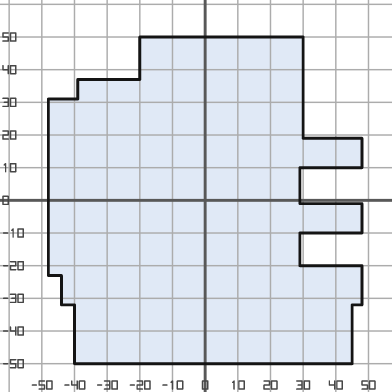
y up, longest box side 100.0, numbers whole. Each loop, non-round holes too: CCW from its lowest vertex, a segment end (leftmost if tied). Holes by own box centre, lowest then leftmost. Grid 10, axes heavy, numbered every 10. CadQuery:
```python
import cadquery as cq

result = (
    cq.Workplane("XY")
    .moveTo(-40.0, -50.0)
    .lineTo(45.0, -50.0)
    .lineTo(45.0, -32.0)
    .lineTo(48.0, -32.0)
    .lineTo(48.0, -20.0)
    .lineTo(29.0, -20.0)
    .lineTo(29.0, -10.0)
    .lineTo(48.0, -10.0)
    .lineTo(48.0, -1.0)
    .lineTo(29.0, -1.0)
    .lineTo(29.0, 10.0)
    .lineTo(48.0, 10.0)
    .lineTo(48.0, 19.0)
    .lineTo(30.0, 19.0)
    .lineTo(30.0, 50.0)
    .lineTo(-20.0, 50.0)
    .lineTo(-20.0, 37.0)
    .lineTo(-39.0, 37.0)
    .lineTo(-39.0, 31.0)
    .lineTo(-48.0, 31.0)
    .lineTo(-48.0, -23.0)
    .lineTo(-44.0, -23.0)
    .lineTo(-44.0, -32.0)
    .lineTo(-40.0, -32.0)
    .close()
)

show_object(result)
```